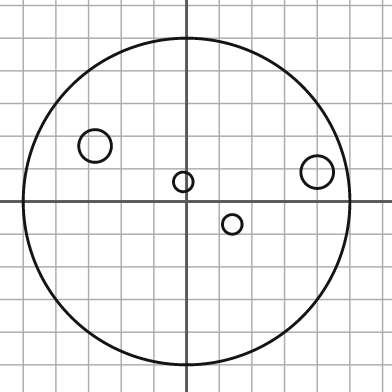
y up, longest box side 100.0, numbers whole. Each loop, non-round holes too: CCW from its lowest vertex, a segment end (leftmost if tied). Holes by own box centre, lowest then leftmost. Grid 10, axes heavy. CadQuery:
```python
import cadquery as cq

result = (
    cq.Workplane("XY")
    .moveTo(0.0, 0.0)
    .circle(50.0)
    .moveTo(14.0, -7.0)
    .circle(3.0)
    .moveTo(-1.0, 6.0)
    .circle(3.0)
    .moveTo(40.0, 9.0)
    .circle(5.0)
    .moveTo(-28.0, 17.0)
    .circle(5.0)
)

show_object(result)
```